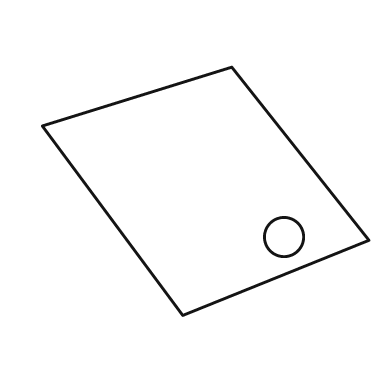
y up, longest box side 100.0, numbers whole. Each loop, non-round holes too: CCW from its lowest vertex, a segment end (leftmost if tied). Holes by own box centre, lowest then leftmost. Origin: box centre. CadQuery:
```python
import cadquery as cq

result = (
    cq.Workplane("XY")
    .moveTo(-7.0, -38.0)
    .lineTo(50.0, -15.0)
    .lineTo(8.0, 38.0)
    .lineTo(-50.0, 20.0)
    .close()
    .moveTo(24.0, -14.0)
    .circle(6.0)
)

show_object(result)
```